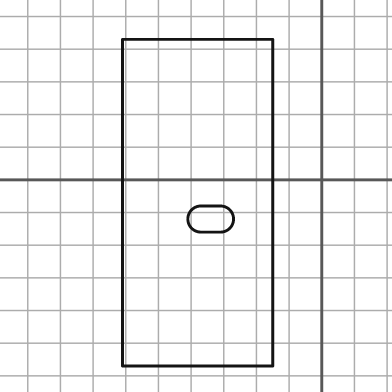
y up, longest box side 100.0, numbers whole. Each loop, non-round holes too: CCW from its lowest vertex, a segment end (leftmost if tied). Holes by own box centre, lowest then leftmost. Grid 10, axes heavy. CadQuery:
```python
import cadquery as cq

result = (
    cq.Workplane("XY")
    .moveTo(-61.0, -57.0)
    .lineTo(-15.0, -57.0)
    .lineTo(-15.0, 43.0)
    .lineTo(-61.0, 43.0)
    .close()
    .moveTo(-37.0, -16.0)
    .lineTo(-31.0, -16.0)
    .threePointArc((-27.0, -12.0), (-31.0, -8.0))
    .lineTo(-37.0, -8.0)
    .threePointArc((-41.0, -12.0), (-37.0, -16.0))
    .close()
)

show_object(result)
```